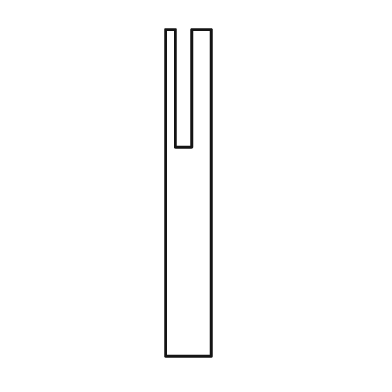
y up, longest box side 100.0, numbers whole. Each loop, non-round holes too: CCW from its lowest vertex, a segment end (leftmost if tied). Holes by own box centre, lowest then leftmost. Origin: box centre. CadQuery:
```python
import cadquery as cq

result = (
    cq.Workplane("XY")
    .moveTo(-7.0, -50.0)
    .lineTo(7.0, -50.0)
    .lineTo(7.0, 50.0)
    .lineTo(1.0, 50.0)
    .lineTo(1.0, 14.0)
    .lineTo(-4.0, 14.0)
    .lineTo(-4.0, 50.0)
    .lineTo(-7.0, 50.0)
    .close()
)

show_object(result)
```